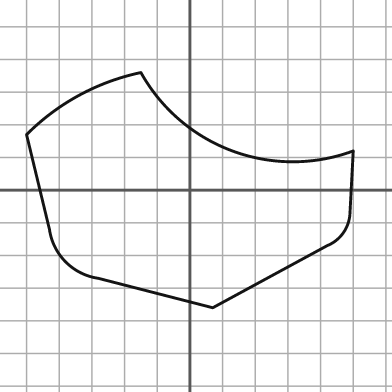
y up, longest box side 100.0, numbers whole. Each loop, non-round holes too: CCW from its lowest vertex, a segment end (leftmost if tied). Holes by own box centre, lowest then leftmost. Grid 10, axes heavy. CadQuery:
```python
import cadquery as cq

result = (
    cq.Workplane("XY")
    .moveTo(7.0, -36.0)
    .lineTo(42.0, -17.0)
    .threePointArc((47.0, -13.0), (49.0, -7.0))
    .lineTo(50.0, 12.0)
    .threePointArc((13.0, 12.0), (-15.0, 36.0))
    .threePointArc((-34.0, 29.0), (-50.0, 17.0))
    .lineTo(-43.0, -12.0)
    .threePointArc((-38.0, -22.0), (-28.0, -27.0))
    .close()
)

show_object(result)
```